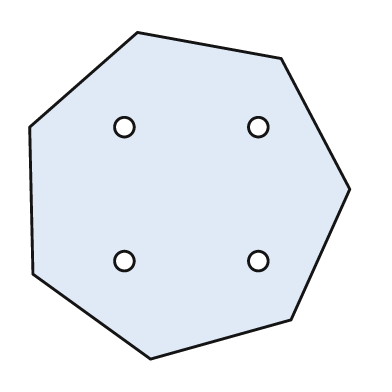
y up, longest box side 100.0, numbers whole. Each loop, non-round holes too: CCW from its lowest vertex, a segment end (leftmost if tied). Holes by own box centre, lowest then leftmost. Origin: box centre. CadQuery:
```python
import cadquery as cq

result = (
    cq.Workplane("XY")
    .moveTo(-12.0, -50.0)
    .lineTo(31.0, -38.0)
    .lineTo(49.0, 2.0)
    .lineTo(28.0, 42.0)
    .lineTo(-16.0, 50.0)
    .lineTo(-49.0, 21.0)
    .lineTo(-48.0, -24.0)
    .close()
    .moveTo(-20.0, -20.0)
    .circle(3.0)
    .moveTo(21.0, -20.0)
    .circle(3.0)
    .moveTo(-20.0, 21.0)
    .circle(3.0)
    .moveTo(21.0, 21.0)
    .circle(3.0)
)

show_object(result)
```